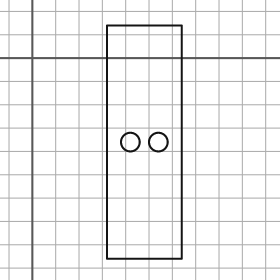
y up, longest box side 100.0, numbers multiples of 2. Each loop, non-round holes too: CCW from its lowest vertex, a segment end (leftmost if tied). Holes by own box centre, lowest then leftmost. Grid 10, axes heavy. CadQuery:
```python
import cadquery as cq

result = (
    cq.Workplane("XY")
    .moveTo(32.0, -86.0)
    .lineTo(64.0, -86.0)
    .lineTo(64.0, 14.0)
    .lineTo(32.0, 14.0)
    .close()
    .moveTo(42.0, -36.0)
    .circle(4.0)
    .moveTo(54.0, -36.0)
    .circle(4.0)
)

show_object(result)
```